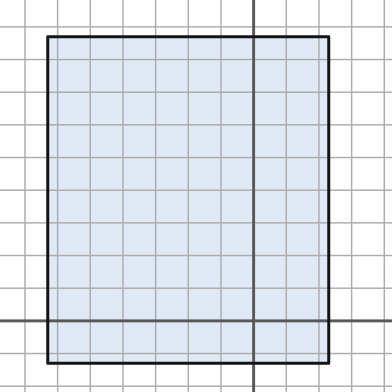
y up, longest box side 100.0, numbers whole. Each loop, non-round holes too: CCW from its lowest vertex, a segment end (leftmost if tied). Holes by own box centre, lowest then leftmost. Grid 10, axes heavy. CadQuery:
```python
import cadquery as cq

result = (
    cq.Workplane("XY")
    .moveTo(-63.0, -13.0)
    .lineTo(23.0, -13.0)
    .lineTo(23.0, 87.0)
    .lineTo(-63.0, 87.0)
    .close()
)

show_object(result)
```